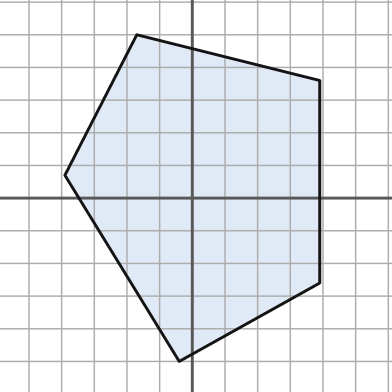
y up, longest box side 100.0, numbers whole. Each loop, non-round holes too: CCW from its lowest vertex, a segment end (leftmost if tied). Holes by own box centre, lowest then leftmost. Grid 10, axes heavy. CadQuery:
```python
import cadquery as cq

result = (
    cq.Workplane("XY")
    .moveTo(-4.0, -50.0)
    .lineTo(39.0, -26.0)
    .lineTo(39.0, 36.0)
    .lineTo(-17.0, 50.0)
    .lineTo(-39.0, 7.0)
    .close()
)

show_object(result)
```